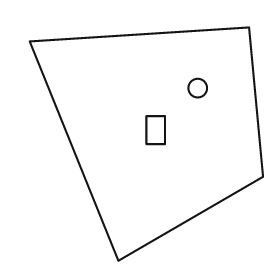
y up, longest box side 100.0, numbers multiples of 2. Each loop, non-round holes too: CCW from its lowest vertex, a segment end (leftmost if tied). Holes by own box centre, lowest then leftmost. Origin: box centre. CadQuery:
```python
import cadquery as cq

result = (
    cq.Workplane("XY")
    .moveTo(-12.0, -50.0)
    .lineTo(50.0, -14.0)
    .lineTo(44.0, 50.0)
    .lineTo(-50.0, 44.0)
    .close()
    .moveTo(0.0, 0.0)
    .lineTo(8.0, 0.0)
    .lineTo(8.0, 12.0)
    .lineTo(0.0, 12.0)
    .close()
    .moveTo(22.0, 24.0)
    .circle(4.0)
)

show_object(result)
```